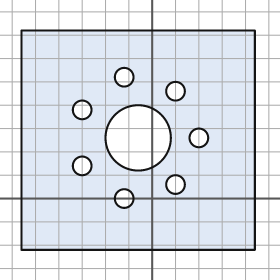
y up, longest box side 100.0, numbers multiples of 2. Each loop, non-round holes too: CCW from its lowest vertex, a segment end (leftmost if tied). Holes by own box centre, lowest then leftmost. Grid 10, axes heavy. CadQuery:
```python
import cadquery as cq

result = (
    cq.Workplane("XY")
    .moveTo(-56.0, -22.0)
    .lineTo(44.0, -22.0)
    .lineTo(44.0, 72.0)
    .lineTo(-56.0, 72.0)
    .close()
    .moveTo(-12.0, 0.0)
    .circle(4.0)
    .moveTo(10.0, 6.0)
    .circle(4.0)
    .moveTo(-30.0, 14.0)
    .circle(4.0)
    .moveTo(-6.0, 26.0)
    .circle(14.0)
    .moveTo(20.0, 26.0)
    .circle(4.0)
    .moveTo(-30.0, 38.0)
    .circle(4.0)
    .moveTo(10.0, 46.0)
    .circle(4.0)
    .moveTo(-12.0, 52.0)
    .circle(4.0)
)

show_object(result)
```